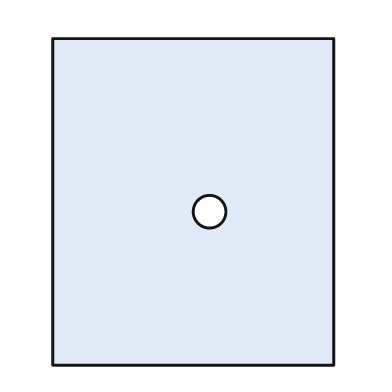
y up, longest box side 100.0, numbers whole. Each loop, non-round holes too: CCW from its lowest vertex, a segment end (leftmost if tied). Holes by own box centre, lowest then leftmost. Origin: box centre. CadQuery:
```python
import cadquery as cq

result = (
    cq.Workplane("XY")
    .moveTo(-43.0, -50.0)
    .lineTo(43.0, -50.0)
    .lineTo(43.0, 50.0)
    .lineTo(-43.0, 50.0)
    .close()
    .moveTo(5.0, -3.0)
    .circle(5.0)
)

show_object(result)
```